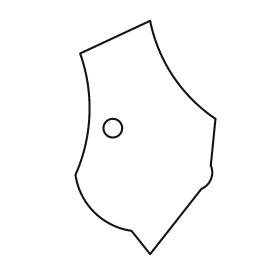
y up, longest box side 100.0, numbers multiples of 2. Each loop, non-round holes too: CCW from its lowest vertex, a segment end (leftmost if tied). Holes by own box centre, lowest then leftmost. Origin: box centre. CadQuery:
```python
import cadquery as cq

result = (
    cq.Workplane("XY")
    .moveTo(2.0, -50.0)
    .lineTo(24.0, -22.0)
    .threePointArc((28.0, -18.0), (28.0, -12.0))
    .lineTo(30.0, 8.0)
    .threePointArc((12.0, 26.0), (2.0, 50.0))
    .lineTo(-28.0, 36.0)
    .threePointArc((-24.0, 10.0), (-30.0, -16.0))
    .threePointArc((-22.0, -32.0), (-6.0, -40.0))
    .close()
    .moveTo(-14.0, 4.0)
    .circle(4.0)
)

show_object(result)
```